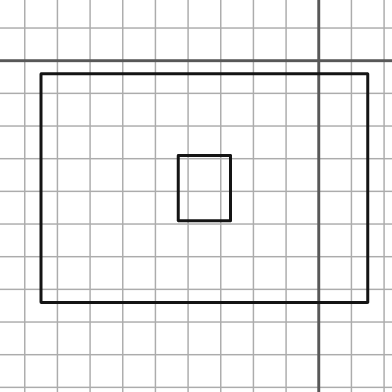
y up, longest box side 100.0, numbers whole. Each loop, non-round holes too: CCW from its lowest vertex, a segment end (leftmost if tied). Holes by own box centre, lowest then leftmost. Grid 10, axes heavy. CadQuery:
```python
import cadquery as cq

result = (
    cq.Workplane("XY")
    .moveTo(-85.0, -74.0)
    .lineTo(15.0, -74.0)
    .lineTo(15.0, -4.0)
    .lineTo(-85.0, -4.0)
    .close()
    .moveTo(-43.0, -49.0)
    .lineTo(-27.0, -49.0)
    .lineTo(-27.0, -29.0)
    .lineTo(-43.0, -29.0)
    .close()
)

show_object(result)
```